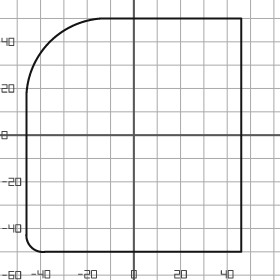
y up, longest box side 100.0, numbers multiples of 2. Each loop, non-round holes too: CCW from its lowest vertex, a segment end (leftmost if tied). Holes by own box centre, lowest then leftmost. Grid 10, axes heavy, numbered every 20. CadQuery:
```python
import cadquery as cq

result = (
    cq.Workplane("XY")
    .moveTo(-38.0, -50.0)
    .lineTo(46.0, -50.0)
    .lineTo(46.0, 50.0)
    .lineTo(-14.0, 50.0)
    .threePointArc((-36.0, 40.0), (-46.0, 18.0))
    .lineTo(-46.0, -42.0)
    .threePointArc((-44.0, -48.0), (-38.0, -50.0))
    .close()
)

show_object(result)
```